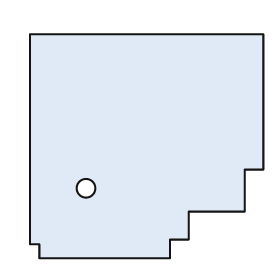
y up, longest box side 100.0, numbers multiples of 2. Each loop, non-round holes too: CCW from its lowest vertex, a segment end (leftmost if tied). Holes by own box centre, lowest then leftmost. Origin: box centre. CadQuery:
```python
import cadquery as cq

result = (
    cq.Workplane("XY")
    .moveTo(-46.0, -48.0)
    .lineTo(10.0, -48.0)
    .lineTo(10.0, -40.0)
    .lineTo(18.0, -40.0)
    .lineTo(18.0, -28.0)
    .lineTo(42.0, -28.0)
    .lineTo(42.0, -10.0)
    .lineTo(50.0, -10.0)
    .lineTo(50.0, 48.0)
    .lineTo(-50.0, 48.0)
    .lineTo(-50.0, -42.0)
    .lineTo(-46.0, -42.0)
    .close()
    .moveTo(-26.0, -18.0)
    .circle(4.0)
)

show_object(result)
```